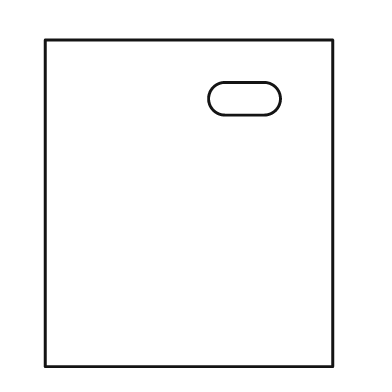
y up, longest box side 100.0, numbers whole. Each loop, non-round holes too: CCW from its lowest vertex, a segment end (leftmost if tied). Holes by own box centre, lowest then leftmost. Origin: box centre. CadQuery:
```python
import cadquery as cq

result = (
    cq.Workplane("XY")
    .moveTo(-44.0, -50.0)
    .lineTo(44.0, -50.0)
    .lineTo(44.0, 50.0)
    .lineTo(-44.0, 50.0)
    .close()
    .moveTo(11.0, 27.0)
    .lineTo(23.0, 27.0)
    .threePointArc((28.0, 32.0), (23.0, 37.0))
    .lineTo(11.0, 37.0)
    .threePointArc((6.0, 32.0), (11.0, 27.0))
    .close()
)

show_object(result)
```